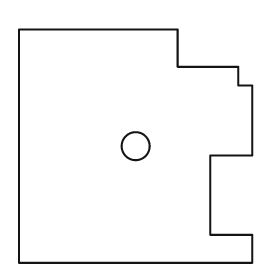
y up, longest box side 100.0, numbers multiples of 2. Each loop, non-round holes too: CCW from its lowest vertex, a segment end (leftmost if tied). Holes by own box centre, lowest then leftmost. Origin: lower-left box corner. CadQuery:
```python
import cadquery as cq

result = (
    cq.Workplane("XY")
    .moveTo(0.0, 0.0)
    .lineTo(100.0, 0.0)
    .lineTo(100.0, 12.0)
    .lineTo(82.0, 12.0)
    .lineTo(82.0, 46.0)
    .lineTo(100.0, 46.0)
    .lineTo(100.0, 76.0)
    .lineTo(94.0, 76.0)
    .lineTo(94.0, 84.0)
    .lineTo(68.0, 84.0)
    .lineTo(68.0, 100.0)
    .lineTo(0.0, 100.0)
    .close()
    .moveTo(50.0, 50.0)
    .circle(6.0)
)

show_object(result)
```